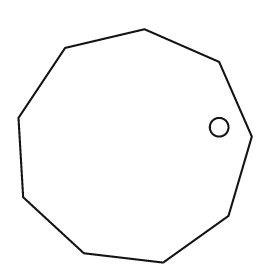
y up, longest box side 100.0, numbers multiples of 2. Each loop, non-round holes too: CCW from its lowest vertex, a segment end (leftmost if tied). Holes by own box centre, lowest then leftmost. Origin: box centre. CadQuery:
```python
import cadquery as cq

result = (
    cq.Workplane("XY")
    .moveTo(12.0, -50.0)
    .lineTo(40.0, -30.0)
    .lineTo(50.0, 4.0)
    .lineTo(36.0, 36.0)
    .lineTo(4.0, 50.0)
    .lineTo(-30.0, 42.0)
    .lineTo(-50.0, 12.0)
    .lineTo(-48.0, -22.0)
    .lineTo(-22.0, -46.0)
    .close()
    .moveTo(36.0, 8.0)
    .circle(4.0)
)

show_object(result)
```